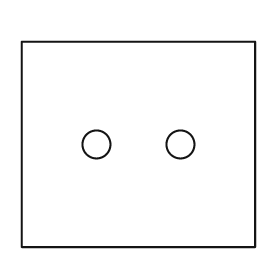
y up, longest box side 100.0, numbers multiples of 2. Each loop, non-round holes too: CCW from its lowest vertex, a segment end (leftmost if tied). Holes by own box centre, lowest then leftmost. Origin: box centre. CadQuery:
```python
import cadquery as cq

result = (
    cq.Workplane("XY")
    .moveTo(-50.0, -44.0)
    .lineTo(50.0, -44.0)
    .lineTo(50.0, 44.0)
    .lineTo(-50.0, 44.0)
    .close()
    .moveTo(-18.0, 0.0)
    .circle(6.0)
    .moveTo(18.0, 0.0)
    .circle(6.0)
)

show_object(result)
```